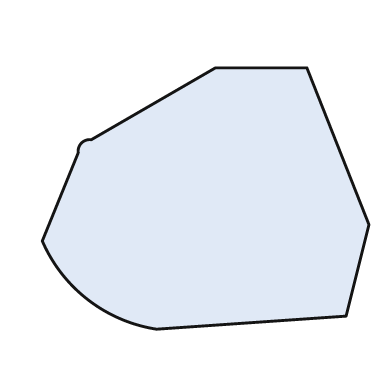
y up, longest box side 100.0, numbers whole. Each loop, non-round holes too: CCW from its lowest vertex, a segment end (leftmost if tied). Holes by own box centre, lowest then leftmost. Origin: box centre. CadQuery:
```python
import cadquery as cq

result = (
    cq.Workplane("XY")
    .moveTo(-15.0, -40.0)
    .lineTo(43.0, -36.0)
    .lineTo(50.0, -8.0)
    .lineTo(31.0, 40.0)
    .lineTo(3.0, 40.0)
    .lineTo(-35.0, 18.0)
    .threePointArc((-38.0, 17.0), (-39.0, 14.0))
    .lineTo(-50.0, -13.0)
    .threePointArc((-36.0, -31.0), (-15.0, -40.0))
    .close()
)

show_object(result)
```